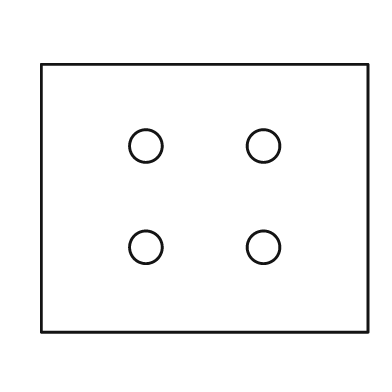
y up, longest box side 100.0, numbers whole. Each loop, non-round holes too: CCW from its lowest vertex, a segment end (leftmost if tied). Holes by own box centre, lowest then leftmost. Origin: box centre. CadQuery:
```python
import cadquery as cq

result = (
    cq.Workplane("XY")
    .moveTo(-50.0, -41.0)
    .lineTo(50.0, -41.0)
    .lineTo(50.0, 41.0)
    .lineTo(-50.0, 41.0)
    .close()
    .moveTo(-18.0, -15.0)
    .circle(5.0)
    .moveTo(18.0, -15.0)
    .circle(5.0)
    .moveTo(-18.0, 16.0)
    .circle(5.0)
    .moveTo(18.0, 16.0)
    .circle(5.0)
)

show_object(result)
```